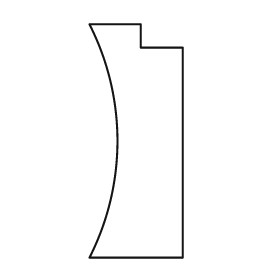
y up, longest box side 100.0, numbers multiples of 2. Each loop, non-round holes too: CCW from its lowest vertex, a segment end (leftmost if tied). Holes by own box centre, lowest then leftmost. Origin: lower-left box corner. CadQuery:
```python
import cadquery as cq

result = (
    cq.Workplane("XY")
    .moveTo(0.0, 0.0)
    .lineTo(40.0, 0.0)
    .lineTo(40.0, 90.0)
    .lineTo(22.0, 90.0)
    .lineTo(22.0, 100.0)
    .lineTo(0.0, 100.0)
    .threePointArc((12.0, 50.0), (0.0, 0.0))
    .close()
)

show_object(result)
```